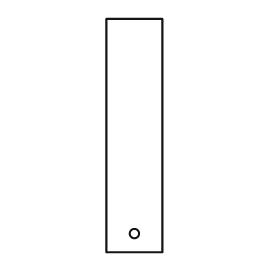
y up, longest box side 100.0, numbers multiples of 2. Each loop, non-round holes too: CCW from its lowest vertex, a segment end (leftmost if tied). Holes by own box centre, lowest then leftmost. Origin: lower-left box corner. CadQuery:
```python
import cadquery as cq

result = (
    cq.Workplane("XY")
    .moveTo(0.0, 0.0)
    .lineTo(24.0, 0.0)
    .lineTo(24.0, 100.0)
    .lineTo(0.0, 100.0)
    .close()
    .moveTo(12.0, 8.0)
    .circle(2.0)
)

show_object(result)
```